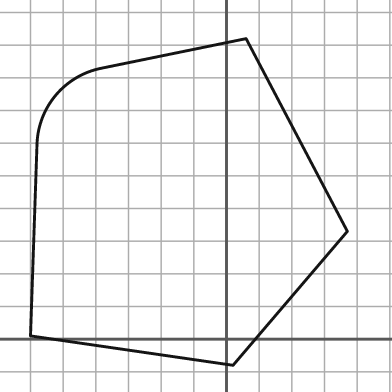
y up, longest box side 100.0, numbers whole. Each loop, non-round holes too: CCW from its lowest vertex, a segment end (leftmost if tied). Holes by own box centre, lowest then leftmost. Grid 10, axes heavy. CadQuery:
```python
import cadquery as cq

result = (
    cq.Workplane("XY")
    .moveTo(2.0, -8.0)
    .lineTo(37.0, 33.0)
    .lineTo(6.0, 92.0)
    .lineTo(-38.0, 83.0)
    .threePointArc((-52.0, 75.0), (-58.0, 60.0))
    .lineTo(-60.0, 1.0)
    .close()
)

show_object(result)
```